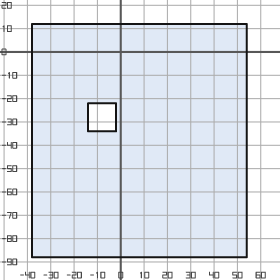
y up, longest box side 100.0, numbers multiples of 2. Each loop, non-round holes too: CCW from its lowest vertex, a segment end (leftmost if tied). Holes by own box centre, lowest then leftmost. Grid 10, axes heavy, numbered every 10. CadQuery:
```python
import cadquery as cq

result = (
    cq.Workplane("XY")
    .moveTo(-38.0, -88.0)
    .lineTo(54.0, -88.0)
    .lineTo(54.0, 12.0)
    .lineTo(-38.0, 12.0)
    .close()
    .moveTo(-14.0, -34.0)
    .lineTo(-2.0, -34.0)
    .lineTo(-2.0, -22.0)
    .lineTo(-14.0, -22.0)
    .close()
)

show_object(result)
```